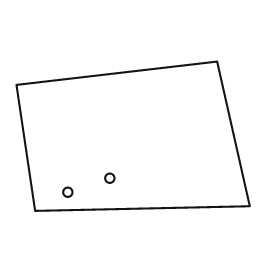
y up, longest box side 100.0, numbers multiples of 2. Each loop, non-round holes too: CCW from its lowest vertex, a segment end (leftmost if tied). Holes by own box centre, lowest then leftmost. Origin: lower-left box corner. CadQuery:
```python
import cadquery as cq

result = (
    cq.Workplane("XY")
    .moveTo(8.0, 0.0)
    .lineTo(100.0, 2.0)
    .lineTo(86.0, 64.0)
    .lineTo(0.0, 54.0)
    .close()
    .moveTo(22.0, 8.0)
    .circle(2.0)
    .moveTo(40.0, 14.0)
    .circle(2.0)
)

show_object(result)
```